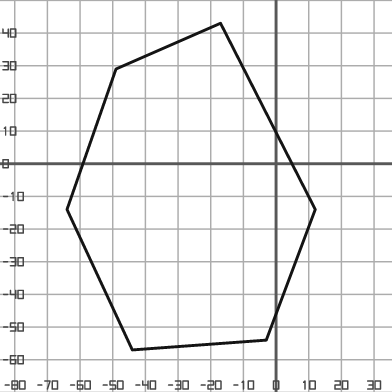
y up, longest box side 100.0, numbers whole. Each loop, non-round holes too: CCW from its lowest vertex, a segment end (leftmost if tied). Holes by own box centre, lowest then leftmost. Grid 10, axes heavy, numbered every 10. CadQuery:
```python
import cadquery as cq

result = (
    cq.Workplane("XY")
    .moveTo(-44.0, -57.0)
    .lineTo(-3.0, -54.0)
    .lineTo(12.0, -14.0)
    .lineTo(-17.0, 43.0)
    .lineTo(-49.0, 29.0)
    .lineTo(-64.0, -14.0)
    .close()
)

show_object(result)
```